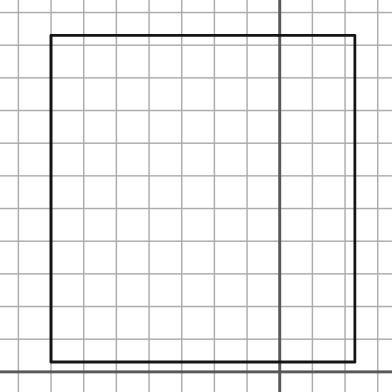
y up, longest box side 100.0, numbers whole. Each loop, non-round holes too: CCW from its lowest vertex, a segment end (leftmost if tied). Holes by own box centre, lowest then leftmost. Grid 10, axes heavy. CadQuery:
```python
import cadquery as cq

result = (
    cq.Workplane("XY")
    .moveTo(-70.0, 3.0)
    .lineTo(23.0, 3.0)
    .lineTo(23.0, 103.0)
    .lineTo(-70.0, 103.0)
    .close()
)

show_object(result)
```